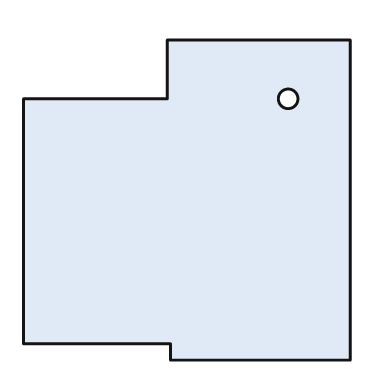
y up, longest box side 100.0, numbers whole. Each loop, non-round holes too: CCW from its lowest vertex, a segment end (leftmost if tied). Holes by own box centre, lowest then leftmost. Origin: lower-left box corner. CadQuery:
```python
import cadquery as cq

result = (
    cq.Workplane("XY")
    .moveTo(45.0, 0.0)
    .lineTo(100.0, 0.0)
    .lineTo(100.0, 98.0)
    .lineTo(44.0, 98.0)
    .lineTo(44.0, 80.0)
    .lineTo(0.0, 80.0)
    .lineTo(0.0, 5.0)
    .lineTo(45.0, 5.0)
    .close()
    .moveTo(81.0, 80.0)
    .circle(3.0)
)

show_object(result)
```